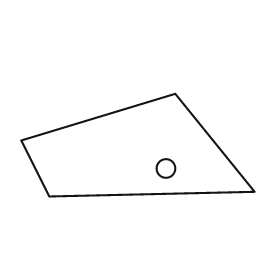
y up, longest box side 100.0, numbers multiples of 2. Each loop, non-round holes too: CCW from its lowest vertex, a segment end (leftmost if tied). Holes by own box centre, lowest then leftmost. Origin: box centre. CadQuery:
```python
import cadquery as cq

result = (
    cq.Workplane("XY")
    .moveTo(-38.0, -22.0)
    .lineTo(50.0, -20.0)
    .lineTo(16.0, 22.0)
    .lineTo(-50.0, 2.0)
    .close()
    .moveTo(12.0, -10.0)
    .circle(4.0)
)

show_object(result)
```